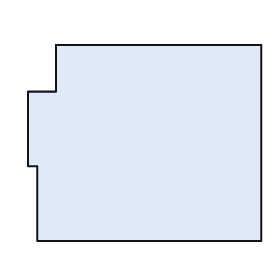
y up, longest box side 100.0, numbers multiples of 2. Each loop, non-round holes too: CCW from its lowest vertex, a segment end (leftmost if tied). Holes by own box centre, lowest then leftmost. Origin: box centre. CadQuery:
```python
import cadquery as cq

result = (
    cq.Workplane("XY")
    .moveTo(-46.0, -42.0)
    .lineTo(50.0, -42.0)
    .lineTo(50.0, 42.0)
    .lineTo(-38.0, 42.0)
    .lineTo(-38.0, 22.0)
    .lineTo(-50.0, 22.0)
    .lineTo(-50.0, -10.0)
    .lineTo(-46.0, -10.0)
    .close()
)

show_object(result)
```